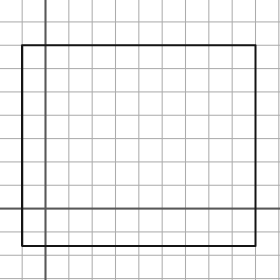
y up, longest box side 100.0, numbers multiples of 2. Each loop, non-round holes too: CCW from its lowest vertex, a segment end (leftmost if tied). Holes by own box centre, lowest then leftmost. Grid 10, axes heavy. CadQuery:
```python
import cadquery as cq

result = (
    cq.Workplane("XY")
    .moveTo(-10.0, -16.0)
    .lineTo(90.0, -16.0)
    .lineTo(90.0, 70.0)
    .lineTo(-10.0, 70.0)
    .close()
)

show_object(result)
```